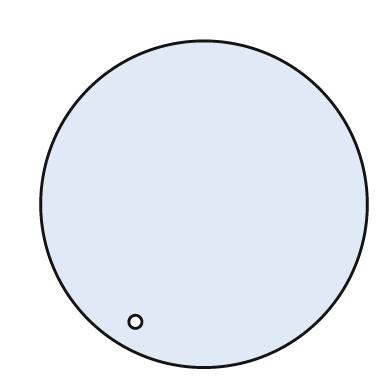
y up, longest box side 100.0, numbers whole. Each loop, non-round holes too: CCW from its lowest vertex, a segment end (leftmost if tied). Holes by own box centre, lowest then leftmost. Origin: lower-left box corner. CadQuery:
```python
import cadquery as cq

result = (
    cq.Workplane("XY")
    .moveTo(50.0, 50.0)
    .circle(50.0)
    .moveTo(29.0, 14.0)
    .circle(2.0)
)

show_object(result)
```